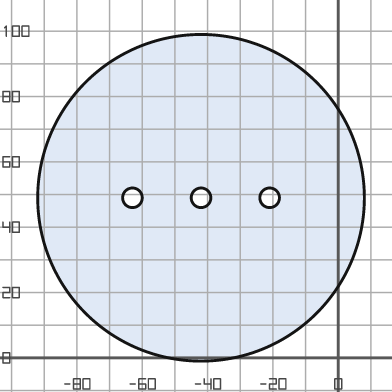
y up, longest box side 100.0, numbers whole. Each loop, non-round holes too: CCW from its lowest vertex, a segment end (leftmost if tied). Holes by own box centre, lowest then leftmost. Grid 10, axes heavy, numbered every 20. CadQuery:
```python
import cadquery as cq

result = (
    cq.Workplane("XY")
    .moveTo(-42.0, 49.0)
    .circle(50.0)
    .moveTo(-63.0, 49.0)
    .circle(3.0)
    .moveTo(-42.0, 49.0)
    .circle(3.0)
    .moveTo(-21.0, 49.0)
    .circle(3.0)
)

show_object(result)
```